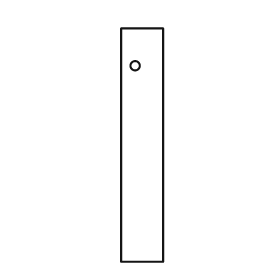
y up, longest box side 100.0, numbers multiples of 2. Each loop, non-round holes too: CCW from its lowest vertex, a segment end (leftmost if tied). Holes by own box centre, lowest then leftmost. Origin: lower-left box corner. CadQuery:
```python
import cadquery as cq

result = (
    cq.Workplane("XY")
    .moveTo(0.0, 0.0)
    .lineTo(18.0, 0.0)
    .lineTo(18.0, 100.0)
    .lineTo(0.0, 100.0)
    .close()
    .moveTo(6.0, 84.0)
    .circle(2.0)
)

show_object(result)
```